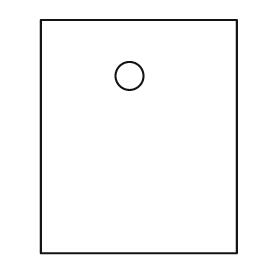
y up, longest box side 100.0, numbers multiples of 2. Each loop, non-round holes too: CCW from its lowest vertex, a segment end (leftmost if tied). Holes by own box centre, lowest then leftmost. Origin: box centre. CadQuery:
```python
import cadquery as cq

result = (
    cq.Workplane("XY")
    .moveTo(-42.0, -50.0)
    .lineTo(42.0, -50.0)
    .lineTo(42.0, 50.0)
    .lineTo(-42.0, 50.0)
    .close()
    .moveTo(-4.0, 26.0)
    .circle(6.0)
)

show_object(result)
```